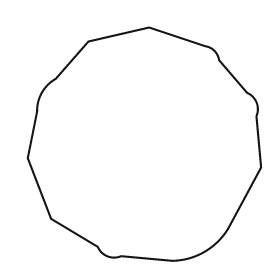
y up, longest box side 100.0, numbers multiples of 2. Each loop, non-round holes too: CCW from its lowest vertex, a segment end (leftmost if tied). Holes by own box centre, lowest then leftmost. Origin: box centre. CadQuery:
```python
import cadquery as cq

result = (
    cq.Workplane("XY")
    .moveTo(12.0, -50.0)
    .threePointArc((26.0, -46.0), (36.0, -36.0))
    .lineTo(50.0, -10.0)
    .lineTo(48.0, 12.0)
    .threePointArc((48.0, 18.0), (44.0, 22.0))
    .lineTo(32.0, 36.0)
    .threePointArc((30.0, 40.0), (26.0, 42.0))
    .lineTo(2.0, 50.0)
    .lineTo(-24.0, 44.0)
    .lineTo(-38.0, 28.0)
    .threePointArc((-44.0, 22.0), (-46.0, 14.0))
    .lineTo(-50.0, -6.0)
    .lineTo(-40.0, -32.0)
    .lineTo(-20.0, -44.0)
    .threePointArc((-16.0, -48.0), (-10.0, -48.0))
    .close()
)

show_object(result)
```